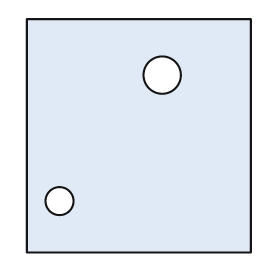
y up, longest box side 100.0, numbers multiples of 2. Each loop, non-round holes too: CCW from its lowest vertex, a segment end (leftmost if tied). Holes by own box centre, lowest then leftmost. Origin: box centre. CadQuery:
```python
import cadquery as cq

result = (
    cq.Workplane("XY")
    .moveTo(-48.0, -50.0)
    .lineTo(48.0, -50.0)
    .lineTo(48.0, 50.0)
    .lineTo(-48.0, 50.0)
    .close()
    .moveTo(-34.0, -28.0)
    .circle(6.0)
    .moveTo(10.0, 26.0)
    .circle(8.0)
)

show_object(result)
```